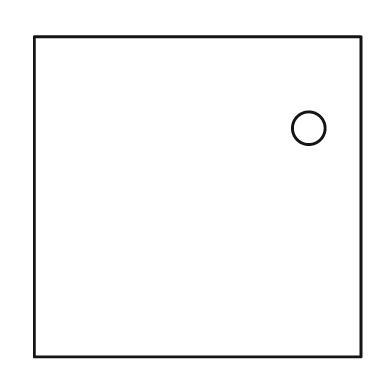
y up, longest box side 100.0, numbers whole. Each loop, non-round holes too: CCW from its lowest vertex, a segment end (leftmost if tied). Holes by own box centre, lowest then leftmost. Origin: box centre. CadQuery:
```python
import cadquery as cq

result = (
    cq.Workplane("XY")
    .moveTo(-50.0, -49.0)
    .lineTo(50.0, -49.0)
    .lineTo(50.0, 49.0)
    .lineTo(-50.0, 49.0)
    .close()
    .moveTo(34.0, 21.0)
    .circle(5.0)
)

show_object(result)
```